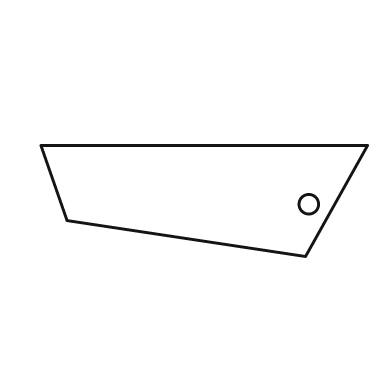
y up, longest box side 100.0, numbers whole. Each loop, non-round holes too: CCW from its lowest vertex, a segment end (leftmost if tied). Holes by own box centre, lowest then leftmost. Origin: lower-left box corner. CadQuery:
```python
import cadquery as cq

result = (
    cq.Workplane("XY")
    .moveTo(81.0, 0.0)
    .lineTo(100.0, 34.0)
    .lineTo(0.0, 34.0)
    .lineTo(8.0, 11.0)
    .close()
    .moveTo(82.0, 16.0)
    .circle(3.0)
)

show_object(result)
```